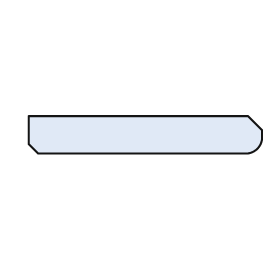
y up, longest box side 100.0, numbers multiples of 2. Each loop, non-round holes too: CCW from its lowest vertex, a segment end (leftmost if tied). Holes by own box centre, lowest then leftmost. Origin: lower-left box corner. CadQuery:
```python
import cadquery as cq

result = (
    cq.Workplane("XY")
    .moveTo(4.0, 0.0)
    .lineTo(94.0, 0.0)
    .threePointArc((98.0, 2.0), (100.0, 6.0))
    .lineTo(100.0, 10.0)
    .lineTo(94.0, 16.0)
    .lineTo(0.0, 16.0)
    .lineTo(0.0, 4.0)
    .close()
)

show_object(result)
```